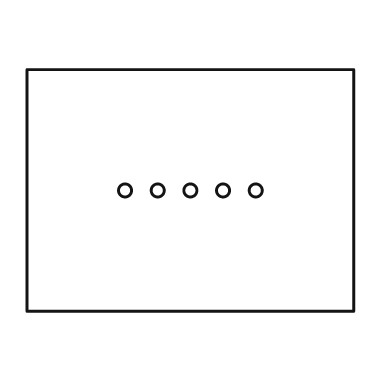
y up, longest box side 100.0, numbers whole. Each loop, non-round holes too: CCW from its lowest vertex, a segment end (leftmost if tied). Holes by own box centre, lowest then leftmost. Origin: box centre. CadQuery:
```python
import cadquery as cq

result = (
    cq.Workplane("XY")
    .moveTo(-50.0, -37.0)
    .lineTo(50.0, -37.0)
    .lineTo(50.0, 37.0)
    .lineTo(-50.0, 37.0)
    .close()
    .moveTo(-20.0, 0.0)
    .circle(2.0)
    .moveTo(-10.0, 0.0)
    .circle(2.0)
    .moveTo(0.0, 0.0)
    .circle(2.0)
    .moveTo(10.0, 0.0)
    .circle(2.0)
    .moveTo(20.0, 0.0)
    .circle(2.0)
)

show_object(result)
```